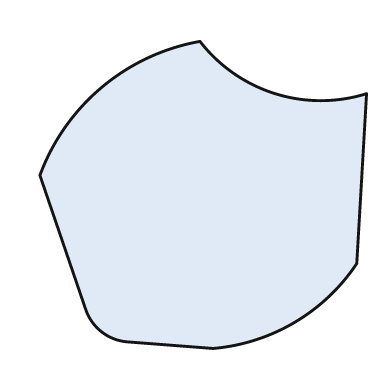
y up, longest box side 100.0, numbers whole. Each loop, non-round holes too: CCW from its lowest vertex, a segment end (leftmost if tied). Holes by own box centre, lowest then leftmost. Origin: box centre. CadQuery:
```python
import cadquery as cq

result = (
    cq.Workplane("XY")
    .moveTo(3.0, -47.0)
    .threePointArc((28.0, -39.0), (47.0, -21.0))
    .lineTo(50.0, 31.0)
    .threePointArc((22.0, 31.0), (-1.0, 47.0))
    .threePointArc((-31.0, 33.0), (-50.0, 6.0))
    .lineTo(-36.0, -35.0)
    .threePointArc((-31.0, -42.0), (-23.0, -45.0))
    .close()
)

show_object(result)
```